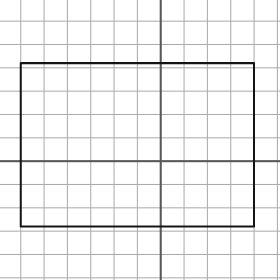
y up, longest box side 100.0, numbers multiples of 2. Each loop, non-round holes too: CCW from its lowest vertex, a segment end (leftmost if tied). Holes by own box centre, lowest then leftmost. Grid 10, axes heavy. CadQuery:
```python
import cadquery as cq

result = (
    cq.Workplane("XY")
    .moveTo(-60.0, -28.0)
    .lineTo(40.0, -28.0)
    .lineTo(40.0, 42.0)
    .lineTo(-60.0, 42.0)
    .close()
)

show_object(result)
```